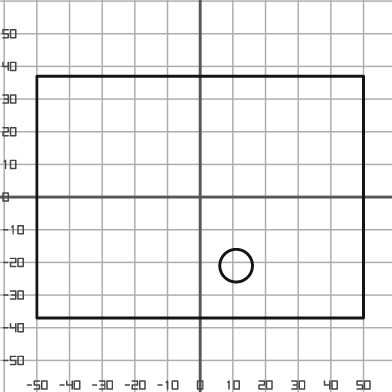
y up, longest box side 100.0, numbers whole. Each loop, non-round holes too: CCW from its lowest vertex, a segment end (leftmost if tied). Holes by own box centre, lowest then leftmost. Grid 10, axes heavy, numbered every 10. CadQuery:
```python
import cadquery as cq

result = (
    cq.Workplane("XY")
    .moveTo(-50.0, -37.0)
    .lineTo(50.0, -37.0)
    .lineTo(50.0, 37.0)
    .lineTo(-50.0, 37.0)
    .close()
    .moveTo(11.0, -21.0)
    .circle(5.0)
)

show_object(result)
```